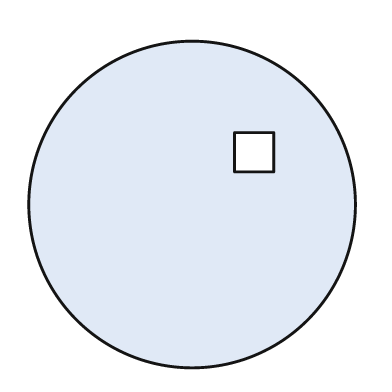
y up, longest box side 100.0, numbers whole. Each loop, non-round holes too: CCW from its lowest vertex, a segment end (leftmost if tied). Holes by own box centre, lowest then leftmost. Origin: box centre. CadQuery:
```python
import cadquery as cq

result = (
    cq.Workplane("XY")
    .moveTo(0.0, 0.0)
    .circle(50.0)
    .moveTo(13.0, 10.0)
    .lineTo(25.0, 10.0)
    .lineTo(25.0, 22.0)
    .lineTo(13.0, 22.0)
    .close()
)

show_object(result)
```